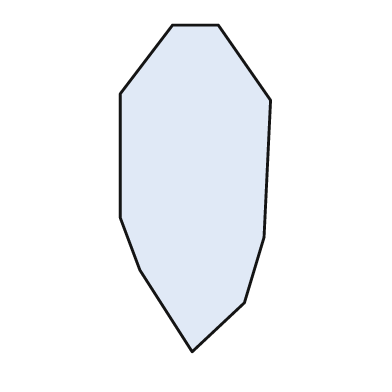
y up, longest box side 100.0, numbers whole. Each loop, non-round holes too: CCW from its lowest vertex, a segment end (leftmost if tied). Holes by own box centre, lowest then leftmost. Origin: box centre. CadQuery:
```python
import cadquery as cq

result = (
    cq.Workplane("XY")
    .moveTo(-1.0, -50.0)
    .lineTo(15.0, -35.0)
    .lineTo(21.0, -15.0)
    .lineTo(23.0, 27.0)
    .lineTo(7.0, 50.0)
    .lineTo(-7.0, 50.0)
    .lineTo(-23.0, 29.0)
    .lineTo(-23.0, -9.0)
    .lineTo(-17.0, -25.0)
    .close()
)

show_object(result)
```